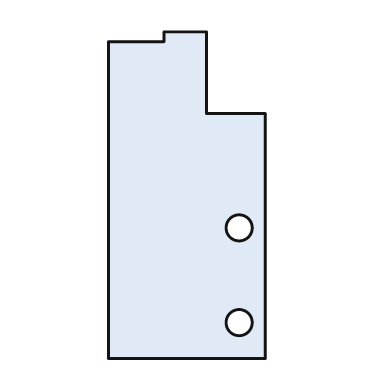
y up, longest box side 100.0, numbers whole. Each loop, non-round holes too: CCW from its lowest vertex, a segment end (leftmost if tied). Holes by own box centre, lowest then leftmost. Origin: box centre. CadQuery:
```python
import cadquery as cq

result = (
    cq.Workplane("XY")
    .moveTo(-24.0, -50.0)
    .lineTo(24.0, -50.0)
    .lineTo(24.0, 25.0)
    .lineTo(6.0, 25.0)
    .lineTo(6.0, 50.0)
    .lineTo(-7.0, 50.0)
    .lineTo(-7.0, 47.0)
    .lineTo(-24.0, 47.0)
    .close()
    .moveTo(16.0, -39.0)
    .circle(4.0)
    .moveTo(16.0, -10.0)
    .circle(4.0)
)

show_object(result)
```